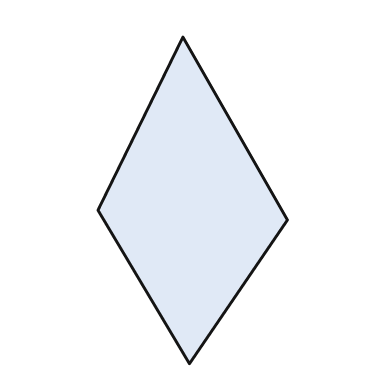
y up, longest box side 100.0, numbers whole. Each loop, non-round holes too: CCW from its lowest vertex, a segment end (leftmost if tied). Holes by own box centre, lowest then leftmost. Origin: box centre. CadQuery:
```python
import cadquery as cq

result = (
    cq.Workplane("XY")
    .moveTo(-1.0, -50.0)
    .lineTo(29.0, -6.0)
    .lineTo(-3.0, 50.0)
    .lineTo(-29.0, -3.0)
    .close()
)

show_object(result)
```